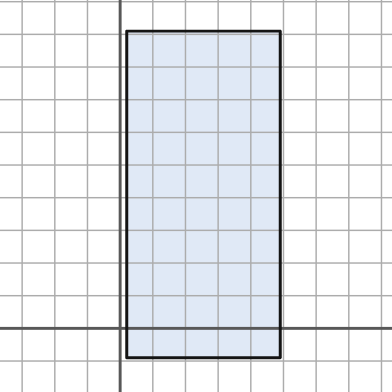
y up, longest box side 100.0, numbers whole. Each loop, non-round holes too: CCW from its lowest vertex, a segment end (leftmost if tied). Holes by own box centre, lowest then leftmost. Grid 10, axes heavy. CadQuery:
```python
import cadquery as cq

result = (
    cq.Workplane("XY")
    .moveTo(2.0, -9.0)
    .lineTo(49.0, -9.0)
    .lineTo(49.0, 91.0)
    .lineTo(2.0, 91.0)
    .close()
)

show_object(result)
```